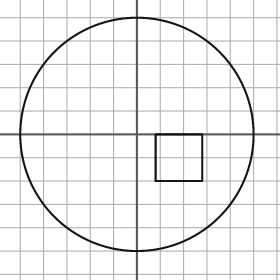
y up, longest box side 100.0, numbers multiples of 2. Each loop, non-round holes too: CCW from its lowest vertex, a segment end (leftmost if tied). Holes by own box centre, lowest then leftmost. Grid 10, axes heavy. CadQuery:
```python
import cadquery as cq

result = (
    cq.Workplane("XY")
    .moveTo(0.0, 0.0)
    .circle(50.0)
    .moveTo(8.0, -20.0)
    .lineTo(28.0, -20.0)
    .lineTo(28.0, 0.0)
    .lineTo(8.0, 0.0)
    .close()
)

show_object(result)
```